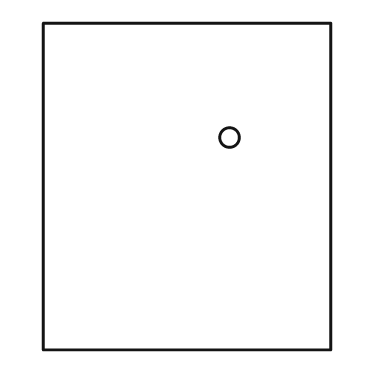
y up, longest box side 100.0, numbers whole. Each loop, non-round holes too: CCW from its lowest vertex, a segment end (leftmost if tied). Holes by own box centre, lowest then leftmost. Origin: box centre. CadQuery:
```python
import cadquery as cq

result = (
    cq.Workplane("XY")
    .moveTo(-44.0, -50.0)
    .lineTo(44.0, -50.0)
    .lineTo(44.0, 50.0)
    .lineTo(-44.0, 50.0)
    .close()
    .moveTo(13.0, 15.0)
    .circle(3.0)
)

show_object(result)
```